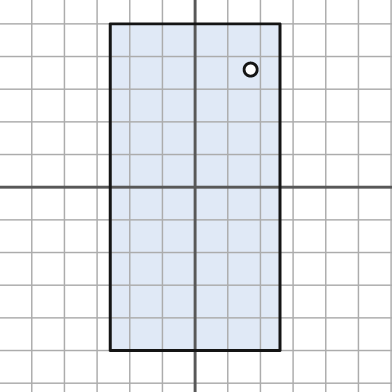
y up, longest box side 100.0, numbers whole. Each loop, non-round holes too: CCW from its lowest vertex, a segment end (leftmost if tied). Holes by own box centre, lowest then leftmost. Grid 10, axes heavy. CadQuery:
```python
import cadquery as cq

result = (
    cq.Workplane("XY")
    .moveTo(-26.0, -50.0)
    .lineTo(26.0, -50.0)
    .lineTo(26.0, 50.0)
    .lineTo(-26.0, 50.0)
    .close()
    .moveTo(17.0, 36.0)
    .circle(2.0)
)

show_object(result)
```